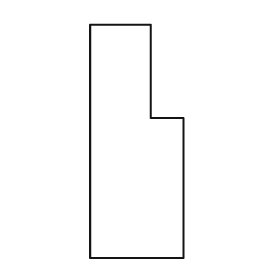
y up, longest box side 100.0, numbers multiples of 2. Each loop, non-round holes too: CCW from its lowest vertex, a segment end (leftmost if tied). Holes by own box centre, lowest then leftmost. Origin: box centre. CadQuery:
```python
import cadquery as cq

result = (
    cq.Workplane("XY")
    .moveTo(-20.0, -50.0)
    .lineTo(20.0, -50.0)
    .lineTo(20.0, 10.0)
    .lineTo(6.0, 10.0)
    .lineTo(6.0, 50.0)
    .lineTo(-20.0, 50.0)
    .close()
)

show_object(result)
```